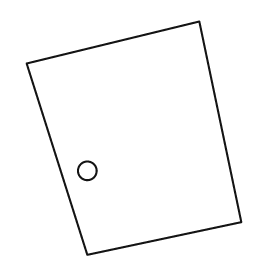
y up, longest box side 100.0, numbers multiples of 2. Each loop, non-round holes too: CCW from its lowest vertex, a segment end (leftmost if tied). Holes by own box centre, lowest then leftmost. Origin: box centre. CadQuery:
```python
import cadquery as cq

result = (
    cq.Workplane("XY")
    .moveTo(-20.0, -50.0)
    .lineTo(46.0, -36.0)
    .lineTo(28.0, 50.0)
    .lineTo(-46.0, 32.0)
    .close()
    .moveTo(-20.0, -14.0)
    .circle(4.0)
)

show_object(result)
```